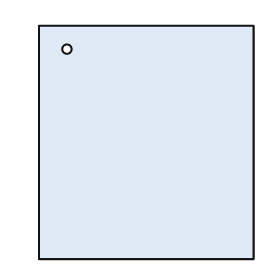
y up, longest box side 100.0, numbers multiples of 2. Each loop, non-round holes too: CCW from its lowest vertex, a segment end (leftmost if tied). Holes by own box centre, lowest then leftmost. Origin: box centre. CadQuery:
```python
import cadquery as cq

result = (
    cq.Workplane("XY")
    .moveTo(-46.0, -50.0)
    .lineTo(46.0, -50.0)
    .lineTo(46.0, 50.0)
    .lineTo(-46.0, 50.0)
    .close()
    .moveTo(-34.0, 40.0)
    .circle(2.0)
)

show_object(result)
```